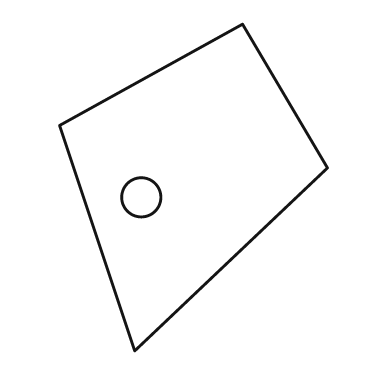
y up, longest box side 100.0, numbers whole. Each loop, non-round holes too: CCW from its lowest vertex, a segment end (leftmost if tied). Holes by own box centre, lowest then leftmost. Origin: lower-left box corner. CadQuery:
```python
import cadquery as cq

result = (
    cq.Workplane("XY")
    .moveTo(23.0, 0.0)
    .lineTo(82.0, 56.0)
    .lineTo(56.0, 100.0)
    .lineTo(0.0, 69.0)
    .close()
    .moveTo(25.0, 47.0)
    .circle(6.0)
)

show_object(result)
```